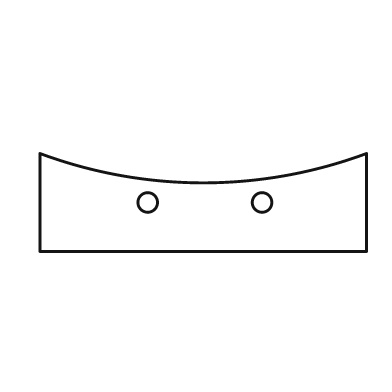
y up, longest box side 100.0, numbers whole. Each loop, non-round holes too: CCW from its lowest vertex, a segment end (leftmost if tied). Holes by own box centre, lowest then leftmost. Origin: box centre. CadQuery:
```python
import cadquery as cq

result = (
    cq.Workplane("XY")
    .moveTo(-50.0, -15.0)
    .lineTo(50.0, -15.0)
    .lineTo(50.0, 15.0)
    .threePointArc((0.0, 6.0), (-50.0, 15.0))
    .close()
    .moveTo(-17.0, 0.0)
    .circle(3.0)
    .moveTo(18.0, 0.0)
    .circle(3.0)
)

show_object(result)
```